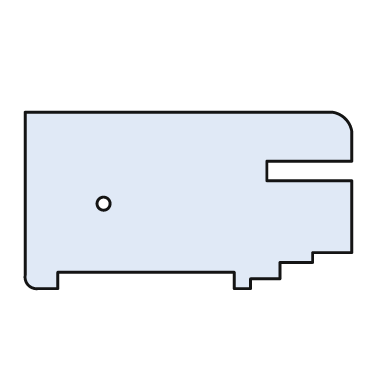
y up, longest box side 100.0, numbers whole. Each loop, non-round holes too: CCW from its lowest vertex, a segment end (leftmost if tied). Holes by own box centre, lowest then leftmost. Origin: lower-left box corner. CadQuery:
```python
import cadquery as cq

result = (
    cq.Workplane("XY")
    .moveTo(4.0, 0.0)
    .lineTo(10.0, 0.0)
    .lineTo(10.0, 5.0)
    .lineTo(64.0, 5.0)
    .lineTo(64.0, 0.0)
    .lineTo(69.0, 0.0)
    .lineTo(69.0, 3.0)
    .lineTo(78.0, 3.0)
    .lineTo(78.0, 8.0)
    .lineTo(88.0, 8.0)
    .lineTo(88.0, 11.0)
    .lineTo(100.0, 11.0)
    .lineTo(100.0, 33.0)
    .lineTo(74.0, 33.0)
    .lineTo(74.0, 39.0)
    .lineTo(100.0, 39.0)
    .lineTo(100.0, 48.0)
    .threePointArc((98.0, 52.0), (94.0, 54.0))
    .lineTo(0.0, 54.0)
    .lineTo(0.0, 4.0)
    .threePointArc((1.0, 1.0), (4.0, 0.0))
    .close()
    .moveTo(24.0, 26.0)
    .circle(2.0)
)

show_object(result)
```